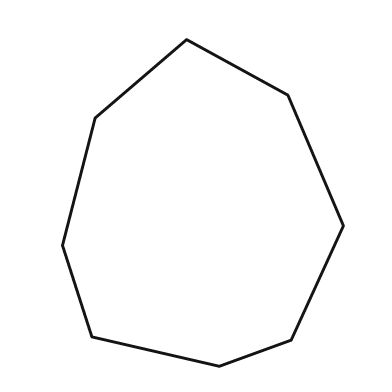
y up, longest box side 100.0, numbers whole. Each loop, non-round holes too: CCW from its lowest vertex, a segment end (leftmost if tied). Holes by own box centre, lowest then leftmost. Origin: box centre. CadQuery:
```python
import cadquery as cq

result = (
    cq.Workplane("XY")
    .moveTo(5.0, -50.0)
    .lineTo(27.0, -42.0)
    .lineTo(43.0, -7.0)
    .lineTo(26.0, 33.0)
    .lineTo(-5.0, 50.0)
    .lineTo(-33.0, 26.0)
    .lineTo(-43.0, -13.0)
    .lineTo(-34.0, -41.0)
    .close()
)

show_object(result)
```